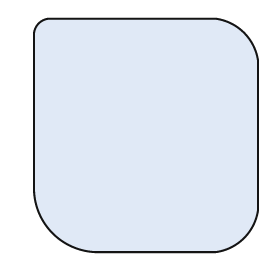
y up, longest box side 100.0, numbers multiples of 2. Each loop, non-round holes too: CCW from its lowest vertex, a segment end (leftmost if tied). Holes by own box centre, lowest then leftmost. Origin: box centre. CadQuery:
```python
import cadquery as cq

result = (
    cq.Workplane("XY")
    .moveTo(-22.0, -50.0)
    .lineTo(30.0, -50.0)
    .threePointArc((42.0, -44.0), (48.0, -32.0))
    .lineTo(48.0, 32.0)
    .threePointArc((42.0, 44.0), (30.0, 50.0))
    .lineTo(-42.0, 50.0)
    .threePointArc((-46.0, 48.0), (-48.0, 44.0))
    .lineTo(-48.0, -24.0)
    .threePointArc((-40.0, -42.0), (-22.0, -50.0))
    .close()
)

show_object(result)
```